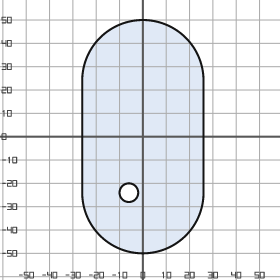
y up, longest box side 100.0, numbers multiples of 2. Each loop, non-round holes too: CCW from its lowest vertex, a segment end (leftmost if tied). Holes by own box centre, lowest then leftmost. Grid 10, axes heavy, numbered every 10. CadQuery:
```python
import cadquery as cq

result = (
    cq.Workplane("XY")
    .moveTo(-26.0, -24.0)
    .threePointArc((0.0, -50.0), (26.0, -24.0))
    .lineTo(26.0, 24.0)
    .threePointArc((0.0, 50.0), (-26.0, 24.0))
    .close()
    .moveTo(-6.0, -24.0)
    .circle(4.0)
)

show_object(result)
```